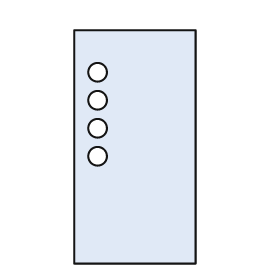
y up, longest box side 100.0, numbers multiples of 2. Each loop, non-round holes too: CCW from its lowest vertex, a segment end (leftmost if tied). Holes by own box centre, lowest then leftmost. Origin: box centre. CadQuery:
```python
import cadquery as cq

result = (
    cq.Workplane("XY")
    .moveTo(-26.0, -50.0)
    .lineTo(26.0, -50.0)
    .lineTo(26.0, 50.0)
    .lineTo(-26.0, 50.0)
    .close()
    .moveTo(-16.0, -4.0)
    .circle(4.0)
    .moveTo(-16.0, 8.0)
    .circle(4.0)
    .moveTo(-16.0, 20.0)
    .circle(4.0)
    .moveTo(-16.0, 32.0)
    .circle(4.0)
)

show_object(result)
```